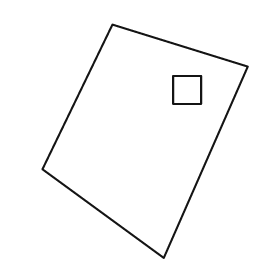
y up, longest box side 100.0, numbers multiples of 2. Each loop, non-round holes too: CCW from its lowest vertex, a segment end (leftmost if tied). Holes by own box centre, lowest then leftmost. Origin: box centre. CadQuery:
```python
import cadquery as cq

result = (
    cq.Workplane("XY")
    .moveTo(8.0, -50.0)
    .lineTo(44.0, 32.0)
    .lineTo(-14.0, 50.0)
    .lineTo(-44.0, -12.0)
    .close()
    .moveTo(12.0, 16.0)
    .lineTo(24.0, 16.0)
    .lineTo(24.0, 28.0)
    .lineTo(12.0, 28.0)
    .close()
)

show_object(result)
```